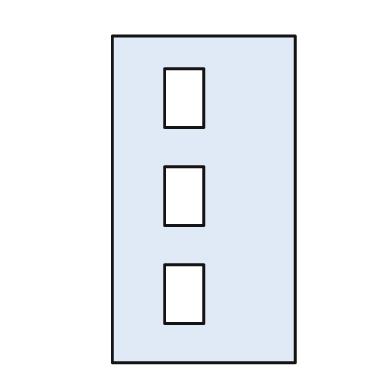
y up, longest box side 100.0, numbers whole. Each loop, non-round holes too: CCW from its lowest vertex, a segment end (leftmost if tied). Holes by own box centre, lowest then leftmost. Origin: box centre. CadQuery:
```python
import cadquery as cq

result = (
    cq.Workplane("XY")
    .moveTo(-28.0, -50.0)
    .lineTo(28.0, -50.0)
    .lineTo(28.0, 50.0)
    .lineTo(-28.0, 50.0)
    .close()
    .moveTo(-12.0, -38.0)
    .lineTo(0.0, -38.0)
    .lineTo(0.0, -20.0)
    .lineTo(-12.0, -20.0)
    .close()
    .moveTo(-12.0, -8.0)
    .lineTo(0.0, -8.0)
    .lineTo(0.0, 10.0)
    .lineTo(-12.0, 10.0)
    .close()
    .moveTo(-12.0, 22.0)
    .lineTo(0.0, 22.0)
    .lineTo(0.0, 40.0)
    .lineTo(-12.0, 40.0)
    .close()
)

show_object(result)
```